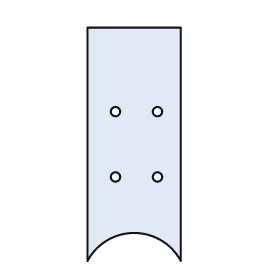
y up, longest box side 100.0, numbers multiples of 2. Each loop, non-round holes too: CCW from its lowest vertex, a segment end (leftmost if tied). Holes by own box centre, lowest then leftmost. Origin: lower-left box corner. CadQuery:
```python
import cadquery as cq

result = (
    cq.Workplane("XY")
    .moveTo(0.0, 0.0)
    .threePointArc((20.0, 12.0), (40.0, 0.0))
    .lineTo(40.0, 100.0)
    .lineTo(0.0, 100.0)
    .close()
    .moveTo(12.0, 36.0)
    .circle(2.0)
    .moveTo(30.0, 36.0)
    .circle(2.0)
    .moveTo(12.0, 64.0)
    .circle(2.0)
    .moveTo(30.0, 64.0)
    .circle(2.0)
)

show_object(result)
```